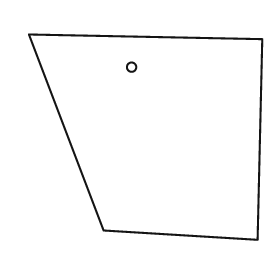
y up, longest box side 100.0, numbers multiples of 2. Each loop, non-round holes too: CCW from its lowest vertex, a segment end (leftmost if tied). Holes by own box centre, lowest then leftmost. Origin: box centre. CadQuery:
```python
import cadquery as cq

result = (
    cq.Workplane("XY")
    .moveTo(48.0, -44.0)
    .lineTo(50.0, 42.0)
    .lineTo(-50.0, 44.0)
    .lineTo(-18.0, -40.0)
    .close()
    .moveTo(-6.0, 30.0)
    .circle(2.0)
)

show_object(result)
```